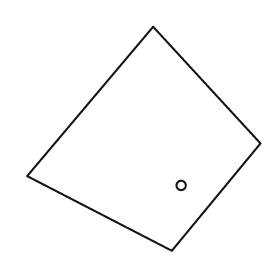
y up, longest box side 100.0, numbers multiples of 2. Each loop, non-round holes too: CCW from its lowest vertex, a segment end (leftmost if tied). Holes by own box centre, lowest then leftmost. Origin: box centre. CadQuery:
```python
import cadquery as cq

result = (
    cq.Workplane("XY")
    .moveTo(12.0, -48.0)
    .lineTo(50.0, -2.0)
    .lineTo(4.0, 48.0)
    .lineTo(-50.0, -16.0)
    .close()
    .moveTo(16.0, -20.0)
    .circle(2.0)
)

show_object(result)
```